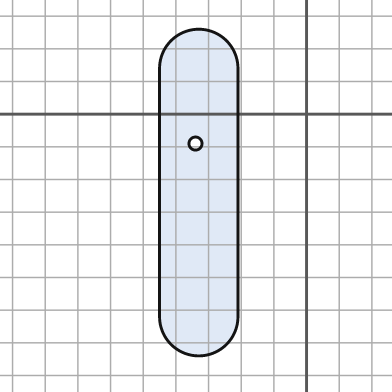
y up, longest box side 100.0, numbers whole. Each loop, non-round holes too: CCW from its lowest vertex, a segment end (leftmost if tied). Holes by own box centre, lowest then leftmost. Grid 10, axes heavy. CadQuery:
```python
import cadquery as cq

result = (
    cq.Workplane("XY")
    .moveTo(-45.0, -62.0)
    .threePointArc((-33.0, -74.0), (-21.0, -62.0))
    .lineTo(-21.0, 14.0)
    .threePointArc((-33.0, 26.0), (-45.0, 14.0))
    .close()
    .moveTo(-34.0, -9.0)
    .circle(2.0)
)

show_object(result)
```